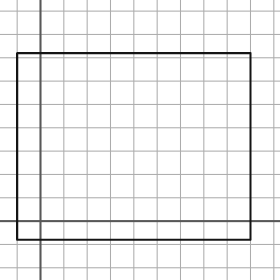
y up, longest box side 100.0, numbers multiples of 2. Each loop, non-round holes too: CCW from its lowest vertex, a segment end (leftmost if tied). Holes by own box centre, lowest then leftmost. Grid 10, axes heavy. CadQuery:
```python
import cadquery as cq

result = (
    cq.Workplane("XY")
    .moveTo(-10.0, -8.0)
    .lineTo(90.0, -8.0)
    .lineTo(90.0, 72.0)
    .lineTo(-10.0, 72.0)
    .close()
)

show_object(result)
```